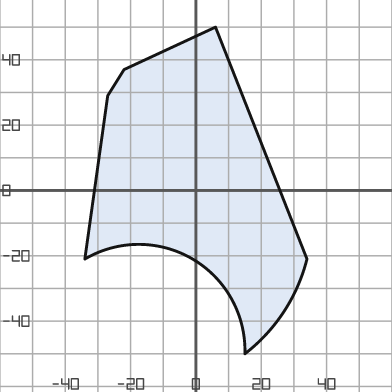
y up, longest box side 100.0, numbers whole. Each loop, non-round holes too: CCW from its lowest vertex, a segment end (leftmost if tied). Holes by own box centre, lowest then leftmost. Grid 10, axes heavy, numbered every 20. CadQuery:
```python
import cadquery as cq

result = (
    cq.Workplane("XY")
    .moveTo(15.0, -50.0)
    .threePointArc((27.0, -37.0), (34.0, -21.0))
    .lineTo(6.0, 50.0)
    .lineTo(-22.0, 37.0)
    .lineTo(-27.0, 29.0)
    .lineTo(-34.0, -21.0)
    .threePointArc((-1.0, -21.0), (15.0, -50.0))
    .close()
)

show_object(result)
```